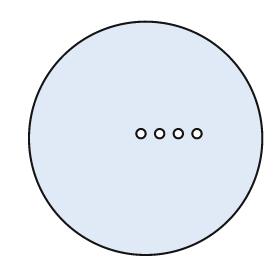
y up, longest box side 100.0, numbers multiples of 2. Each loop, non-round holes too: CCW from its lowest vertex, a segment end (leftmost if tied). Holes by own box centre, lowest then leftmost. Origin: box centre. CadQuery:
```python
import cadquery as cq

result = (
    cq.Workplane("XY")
    .moveTo(0.0, 0.0)
    .circle(50.0)
    .moveTo(-2.0, 2.0)
    .circle(2.0)
    .moveTo(6.0, 2.0)
    .circle(2.0)
    .moveTo(14.0, 2.0)
    .circle(2.0)
    .moveTo(22.0, 2.0)
    .circle(2.0)
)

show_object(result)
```